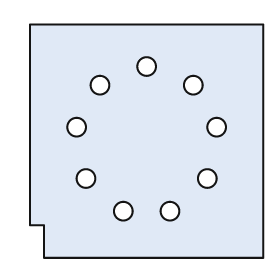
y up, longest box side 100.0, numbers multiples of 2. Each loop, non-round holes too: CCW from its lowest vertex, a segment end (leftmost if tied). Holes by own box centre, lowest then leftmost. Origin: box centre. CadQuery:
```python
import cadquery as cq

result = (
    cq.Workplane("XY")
    .moveTo(-44.0, -50.0)
    .lineTo(50.0, -50.0)
    .lineTo(50.0, 50.0)
    .lineTo(-50.0, 50.0)
    .lineTo(-50.0, -36.0)
    .lineTo(-44.0, -36.0)
    .close()
    .moveTo(-10.0, -30.0)
    .circle(4.0)
    .moveTo(10.0, -30.0)
    .circle(4.0)
    .moveTo(-26.0, -16.0)
    .circle(4.0)
    .moveTo(26.0, -16.0)
    .circle(4.0)
    .moveTo(-30.0, 6.0)
    .circle(4.0)
    .moveTo(30.0, 6.0)
    .circle(4.0)
    .moveTo(-20.0, 24.0)
    .circle(4.0)
    .moveTo(20.0, 24.0)
    .circle(4.0)
    .moveTo(0.0, 32.0)
    .circle(4.0)
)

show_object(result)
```